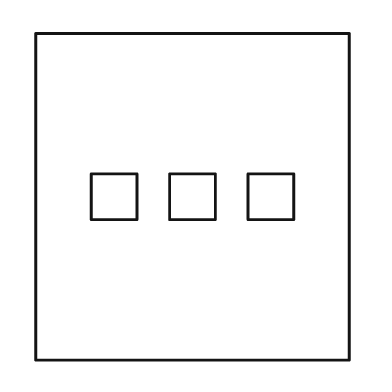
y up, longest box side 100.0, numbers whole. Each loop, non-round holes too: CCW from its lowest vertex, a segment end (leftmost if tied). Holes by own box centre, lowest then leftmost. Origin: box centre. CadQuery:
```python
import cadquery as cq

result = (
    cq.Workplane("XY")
    .moveTo(-48.0, -50.0)
    .lineTo(48.0, -50.0)
    .lineTo(48.0, 50.0)
    .lineTo(-48.0, 50.0)
    .close()
    .moveTo(-31.0, -7.0)
    .lineTo(-17.0, -7.0)
    .lineTo(-17.0, 7.0)
    .lineTo(-31.0, 7.0)
    .close()
    .moveTo(-7.0, -7.0)
    .lineTo(7.0, -7.0)
    .lineTo(7.0, 7.0)
    .lineTo(-7.0, 7.0)
    .close()
    .moveTo(17.0, -7.0)
    .lineTo(31.0, -7.0)
    .lineTo(31.0, 7.0)
    .lineTo(17.0, 7.0)
    .close()
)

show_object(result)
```